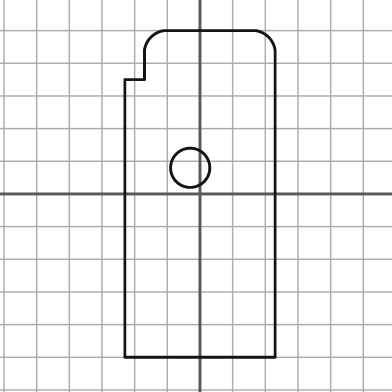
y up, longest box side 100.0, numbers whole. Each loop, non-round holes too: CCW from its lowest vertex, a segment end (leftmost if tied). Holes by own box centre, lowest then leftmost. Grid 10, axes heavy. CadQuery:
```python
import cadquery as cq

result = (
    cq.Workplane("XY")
    .moveTo(-23.0, -50.0)
    .lineTo(23.0, -50.0)
    .lineTo(23.0, 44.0)
    .threePointArc((21.0, 48.0), (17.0, 50.0))
    .lineTo(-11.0, 50.0)
    .threePointArc((-15.0, 48.0), (-17.0, 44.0))
    .lineTo(-17.0, 35.0)
    .lineTo(-23.0, 35.0)
    .close()
    .moveTo(-3.0, 8.0)
    .circle(6.0)
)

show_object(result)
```